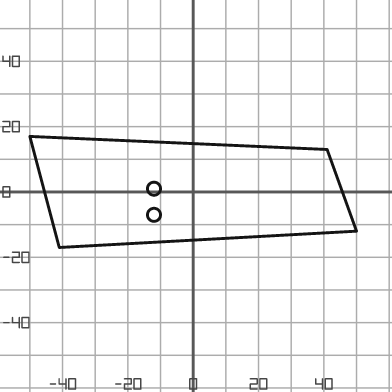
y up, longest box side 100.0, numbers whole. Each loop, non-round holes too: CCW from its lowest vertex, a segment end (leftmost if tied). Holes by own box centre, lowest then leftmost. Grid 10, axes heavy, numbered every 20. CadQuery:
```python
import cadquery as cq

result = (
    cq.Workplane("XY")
    .moveTo(-41.0, -17.0)
    .lineTo(50.0, -12.0)
    .lineTo(41.0, 13.0)
    .lineTo(-50.0, 17.0)
    .close()
    .moveTo(-12.0, -7.0)
    .circle(2.0)
    .moveTo(-12.0, 1.0)
    .circle(2.0)
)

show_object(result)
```